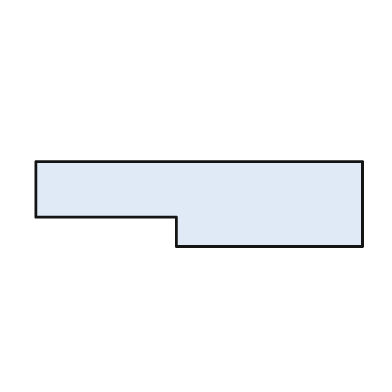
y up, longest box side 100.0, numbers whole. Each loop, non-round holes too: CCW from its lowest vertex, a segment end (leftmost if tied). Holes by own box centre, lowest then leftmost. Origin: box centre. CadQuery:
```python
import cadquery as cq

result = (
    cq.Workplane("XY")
    .moveTo(-7.0, -13.0)
    .lineTo(50.0, -13.0)
    .lineTo(50.0, 13.0)
    .lineTo(-50.0, 13.0)
    .lineTo(-50.0, -4.0)
    .lineTo(-7.0, -4.0)
    .close()
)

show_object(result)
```